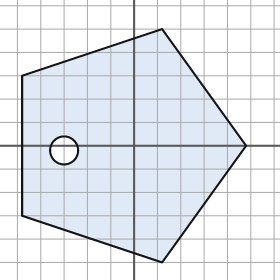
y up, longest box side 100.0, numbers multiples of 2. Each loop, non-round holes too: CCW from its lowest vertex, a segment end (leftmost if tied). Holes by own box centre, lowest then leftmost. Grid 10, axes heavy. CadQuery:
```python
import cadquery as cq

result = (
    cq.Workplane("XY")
    .moveTo(12.0, -50.0)
    .lineTo(48.0, 0.0)
    .lineTo(12.0, 50.0)
    .lineTo(-48.0, 30.0)
    .lineTo(-48.0, -30.0)
    .close()
    .moveTo(-30.0, -2.0)
    .circle(6.0)
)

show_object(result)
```